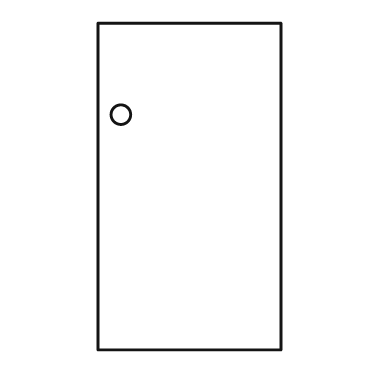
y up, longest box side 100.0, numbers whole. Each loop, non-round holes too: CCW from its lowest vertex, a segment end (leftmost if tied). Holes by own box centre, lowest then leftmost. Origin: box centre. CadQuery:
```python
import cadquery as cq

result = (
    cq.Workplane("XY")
    .moveTo(-28.0, -50.0)
    .lineTo(28.0, -50.0)
    .lineTo(28.0, 50.0)
    .lineTo(-28.0, 50.0)
    .close()
    .moveTo(-21.0, 22.0)
    .circle(3.0)
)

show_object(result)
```